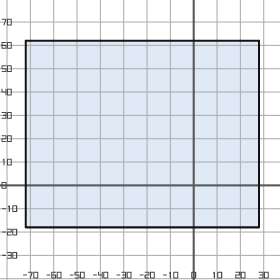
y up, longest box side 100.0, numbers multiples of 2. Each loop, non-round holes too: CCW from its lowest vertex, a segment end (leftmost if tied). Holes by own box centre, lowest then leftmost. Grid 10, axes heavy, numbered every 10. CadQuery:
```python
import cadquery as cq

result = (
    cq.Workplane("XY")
    .moveTo(-72.0, -18.0)
    .lineTo(28.0, -18.0)
    .lineTo(28.0, 62.0)
    .lineTo(-72.0, 62.0)
    .close()
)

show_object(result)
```